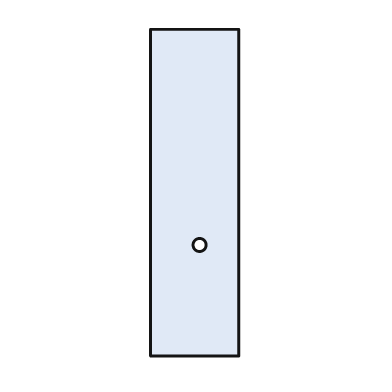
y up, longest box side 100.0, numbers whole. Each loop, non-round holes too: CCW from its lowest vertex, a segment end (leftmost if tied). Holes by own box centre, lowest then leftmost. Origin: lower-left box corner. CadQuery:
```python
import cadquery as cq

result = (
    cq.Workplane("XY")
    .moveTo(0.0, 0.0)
    .lineTo(27.0, 0.0)
    .lineTo(27.0, 100.0)
    .lineTo(0.0, 100.0)
    .close()
    .moveTo(15.0, 34.0)
    .circle(2.0)
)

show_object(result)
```